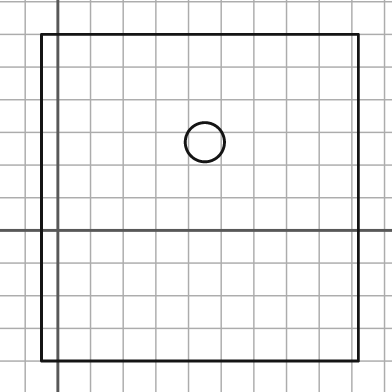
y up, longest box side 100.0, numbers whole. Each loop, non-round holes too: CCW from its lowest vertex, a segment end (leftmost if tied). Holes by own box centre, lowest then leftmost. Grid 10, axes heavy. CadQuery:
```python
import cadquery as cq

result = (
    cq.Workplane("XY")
    .moveTo(-5.0, -40.0)
    .lineTo(92.0, -40.0)
    .lineTo(92.0, 60.0)
    .lineTo(-5.0, 60.0)
    .close()
    .moveTo(45.0, 27.0)
    .circle(6.0)
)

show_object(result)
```